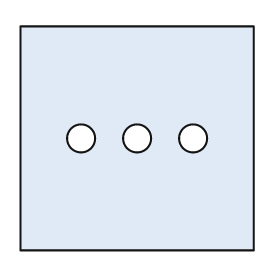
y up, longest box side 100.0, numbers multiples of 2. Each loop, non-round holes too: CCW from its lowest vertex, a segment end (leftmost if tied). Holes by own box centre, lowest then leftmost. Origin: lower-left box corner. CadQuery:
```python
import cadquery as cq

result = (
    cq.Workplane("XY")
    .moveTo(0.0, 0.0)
    .lineTo(100.0, 0.0)
    .lineTo(100.0, 96.0)
    .lineTo(0.0, 96.0)
    .close()
    .moveTo(26.0, 48.0)
    .circle(6.0)
    .moveTo(50.0, 48.0)
    .circle(6.0)
    .moveTo(74.0, 48.0)
    .circle(6.0)
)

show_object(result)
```